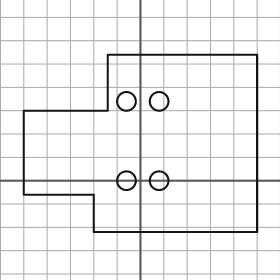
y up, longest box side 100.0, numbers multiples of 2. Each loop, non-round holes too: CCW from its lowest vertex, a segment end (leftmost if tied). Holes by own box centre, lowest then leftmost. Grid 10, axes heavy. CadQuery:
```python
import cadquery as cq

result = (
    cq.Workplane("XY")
    .moveTo(-20.0, -22.0)
    .lineTo(50.0, -22.0)
    .lineTo(50.0, 54.0)
    .lineTo(-14.0, 54.0)
    .lineTo(-14.0, 30.0)
    .lineTo(-50.0, 30.0)
    .lineTo(-50.0, -6.0)
    .lineTo(-20.0, -6.0)
    .close()
    .moveTo(-6.0, 0.0)
    .circle(4.0)
    .moveTo(8.0, 0.0)
    .circle(4.0)
    .moveTo(-6.0, 34.0)
    .circle(4.0)
    .moveTo(8.0, 34.0)
    .circle(4.0)
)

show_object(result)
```